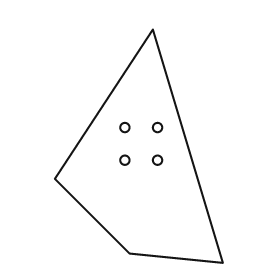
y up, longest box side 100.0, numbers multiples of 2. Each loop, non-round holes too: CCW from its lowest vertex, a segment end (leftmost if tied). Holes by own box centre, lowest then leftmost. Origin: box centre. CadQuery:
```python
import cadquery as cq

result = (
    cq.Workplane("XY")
    .moveTo(36.0, -50.0)
    .lineTo(6.0, 50.0)
    .lineTo(-36.0, -14.0)
    .lineTo(-4.0, -46.0)
    .close()
    .moveTo(-6.0, -6.0)
    .circle(2.0)
    .moveTo(8.0, -6.0)
    .circle(2.0)
    .moveTo(-6.0, 8.0)
    .circle(2.0)
    .moveTo(8.0, 8.0)
    .circle(2.0)
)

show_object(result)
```